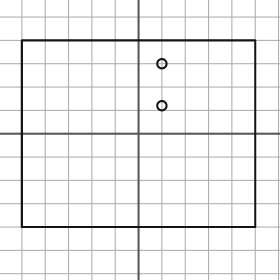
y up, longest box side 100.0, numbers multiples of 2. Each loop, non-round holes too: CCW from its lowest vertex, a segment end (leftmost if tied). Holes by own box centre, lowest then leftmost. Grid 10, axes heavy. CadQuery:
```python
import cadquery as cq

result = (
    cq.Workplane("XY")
    .moveTo(-50.0, -40.0)
    .lineTo(50.0, -40.0)
    .lineTo(50.0, 40.0)
    .lineTo(-50.0, 40.0)
    .close()
    .moveTo(10.0, 12.0)
    .circle(2.0)
    .moveTo(10.0, 30.0)
    .circle(2.0)
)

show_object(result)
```